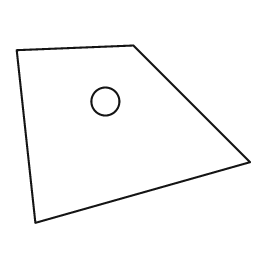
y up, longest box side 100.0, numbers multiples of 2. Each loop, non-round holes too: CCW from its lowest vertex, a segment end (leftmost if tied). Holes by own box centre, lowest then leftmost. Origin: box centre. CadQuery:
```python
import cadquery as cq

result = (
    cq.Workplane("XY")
    .moveTo(-42.0, -38.0)
    .lineTo(50.0, -12.0)
    .lineTo(0.0, 38.0)
    .lineTo(-50.0, 36.0)
    .close()
    .moveTo(-12.0, 14.0)
    .circle(6.0)
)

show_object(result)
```